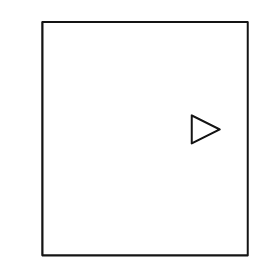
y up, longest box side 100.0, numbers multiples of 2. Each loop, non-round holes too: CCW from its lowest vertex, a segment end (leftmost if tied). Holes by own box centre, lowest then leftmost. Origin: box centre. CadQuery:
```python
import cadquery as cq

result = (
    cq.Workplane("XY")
    .moveTo(-44.0, -50.0)
    .lineTo(44.0, -50.0)
    .lineTo(44.0, 50.0)
    .lineTo(-44.0, 50.0)
    .close()
    .moveTo(20.0, -2.0)
    .lineTo(32.0, 4.0)
    .lineTo(20.0, 10.0)
    .close()
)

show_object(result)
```